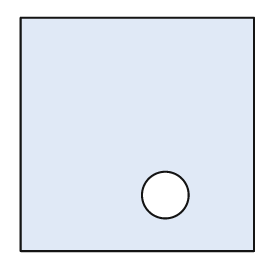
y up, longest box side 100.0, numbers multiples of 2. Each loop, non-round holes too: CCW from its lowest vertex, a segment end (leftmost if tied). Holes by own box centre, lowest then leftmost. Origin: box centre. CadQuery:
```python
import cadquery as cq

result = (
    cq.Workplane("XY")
    .moveTo(-50.0, -50.0)
    .lineTo(50.0, -50.0)
    .lineTo(50.0, 50.0)
    .lineTo(-50.0, 50.0)
    .close()
    .moveTo(12.0, -26.0)
    .circle(10.0)
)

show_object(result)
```